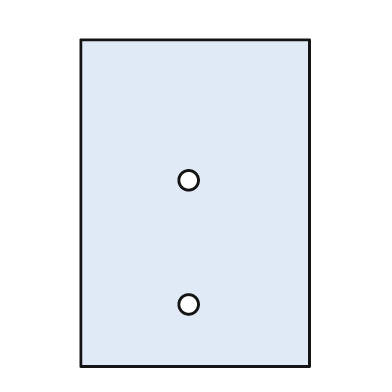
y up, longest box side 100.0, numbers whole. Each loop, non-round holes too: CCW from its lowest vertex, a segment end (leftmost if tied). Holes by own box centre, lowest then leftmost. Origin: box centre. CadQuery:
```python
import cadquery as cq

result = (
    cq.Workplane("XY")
    .moveTo(-35.0, -50.0)
    .lineTo(35.0, -50.0)
    .lineTo(35.0, 50.0)
    .lineTo(-35.0, 50.0)
    .close()
    .moveTo(-2.0, -31.0)
    .circle(3.0)
    .moveTo(-2.0, 7.0)
    .circle(3.0)
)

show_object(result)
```